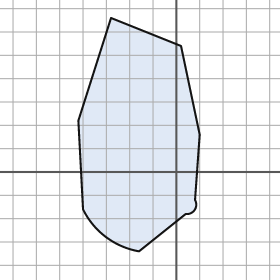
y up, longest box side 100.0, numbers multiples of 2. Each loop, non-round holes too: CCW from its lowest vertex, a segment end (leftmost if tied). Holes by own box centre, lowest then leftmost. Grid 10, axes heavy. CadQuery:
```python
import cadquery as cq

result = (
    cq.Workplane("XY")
    .moveTo(-16.0, -34.0)
    .lineTo(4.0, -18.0)
    .threePointArc((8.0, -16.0), (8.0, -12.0))
    .lineTo(10.0, 16.0)
    .lineTo(2.0, 54.0)
    .lineTo(-28.0, 66.0)
    .lineTo(-42.0, 22.0)
    .lineTo(-40.0, -16.0)
    .threePointArc((-30.0, -28.0), (-16.0, -34.0))
    .close()
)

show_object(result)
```